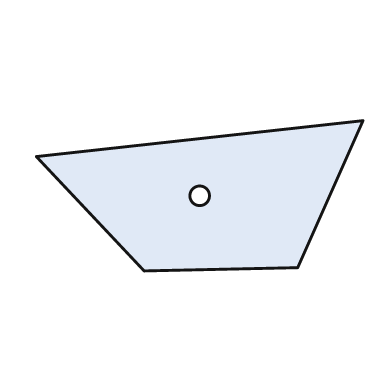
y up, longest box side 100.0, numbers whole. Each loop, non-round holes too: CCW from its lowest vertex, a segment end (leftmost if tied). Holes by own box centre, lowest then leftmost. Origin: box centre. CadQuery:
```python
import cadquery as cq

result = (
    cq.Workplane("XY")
    .moveTo(-17.0, -23.0)
    .lineTo(30.0, -22.0)
    .lineTo(50.0, 23.0)
    .lineTo(-50.0, 12.0)
    .close()
    .moveTo(0.0, 0.0)
    .circle(3.0)
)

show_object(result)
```